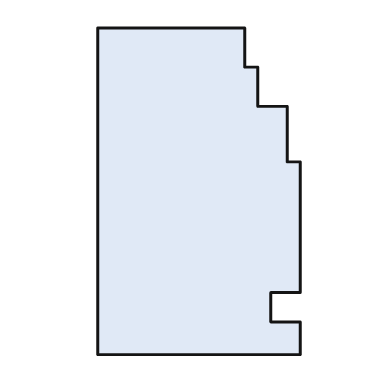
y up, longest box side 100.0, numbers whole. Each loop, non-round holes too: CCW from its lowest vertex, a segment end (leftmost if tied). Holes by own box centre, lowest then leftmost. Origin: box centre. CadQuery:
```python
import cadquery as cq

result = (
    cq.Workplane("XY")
    .moveTo(-31.0, -50.0)
    .lineTo(31.0, -50.0)
    .lineTo(31.0, -40.0)
    .lineTo(22.0, -40.0)
    .lineTo(22.0, -31.0)
    .lineTo(31.0, -31.0)
    .lineTo(31.0, 9.0)
    .lineTo(27.0, 9.0)
    .lineTo(27.0, 26.0)
    .lineTo(18.0, 26.0)
    .lineTo(18.0, 38.0)
    .lineTo(14.0, 38.0)
    .lineTo(14.0, 50.0)
    .lineTo(-31.0, 50.0)
    .close()
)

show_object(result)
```